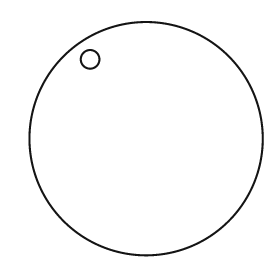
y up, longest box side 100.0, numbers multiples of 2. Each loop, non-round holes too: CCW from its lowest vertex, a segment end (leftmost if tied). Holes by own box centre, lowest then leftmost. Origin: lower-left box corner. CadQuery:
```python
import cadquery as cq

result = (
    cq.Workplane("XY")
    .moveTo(50.0, 50.0)
    .circle(50.0)
    .moveTo(26.0, 84.0)
    .circle(4.0)
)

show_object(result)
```